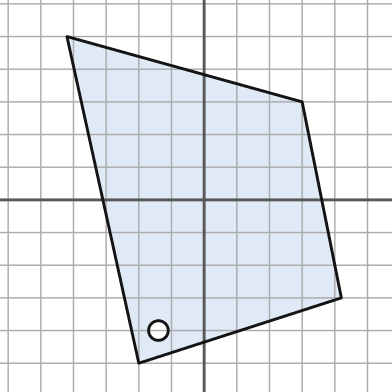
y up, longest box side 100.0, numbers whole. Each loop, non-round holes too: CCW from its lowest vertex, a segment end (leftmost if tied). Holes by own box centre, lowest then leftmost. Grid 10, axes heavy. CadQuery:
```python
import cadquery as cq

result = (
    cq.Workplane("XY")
    .moveTo(-20.0, -50.0)
    .lineTo(42.0, -30.0)
    .lineTo(30.0, 30.0)
    .lineTo(-42.0, 50.0)
    .close()
    .moveTo(-14.0, -40.0)
    .circle(3.0)
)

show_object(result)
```